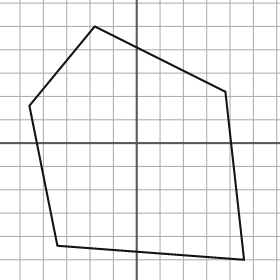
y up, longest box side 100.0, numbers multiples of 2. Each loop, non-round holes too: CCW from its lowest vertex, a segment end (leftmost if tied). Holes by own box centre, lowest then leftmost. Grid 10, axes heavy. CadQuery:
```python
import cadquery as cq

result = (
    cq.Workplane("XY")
    .moveTo(46.0, -50.0)
    .lineTo(38.0, 22.0)
    .lineTo(-18.0, 50.0)
    .lineTo(-46.0, 16.0)
    .lineTo(-34.0, -44.0)
    .close()
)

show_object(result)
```